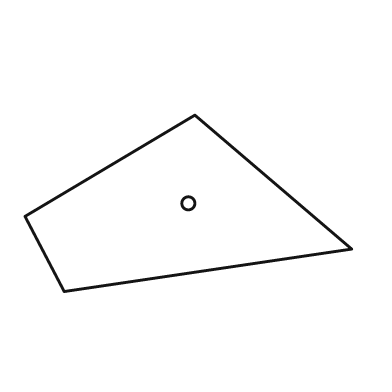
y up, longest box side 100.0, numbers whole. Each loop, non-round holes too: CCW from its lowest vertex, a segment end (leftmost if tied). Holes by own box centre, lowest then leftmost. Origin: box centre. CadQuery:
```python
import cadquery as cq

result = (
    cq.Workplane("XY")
    .moveTo(-38.0, -27.0)
    .lineTo(50.0, -14.0)
    .lineTo(2.0, 27.0)
    .lineTo(-50.0, -4.0)
    .close()
    .moveTo(0.0, 0.0)
    .circle(2.0)
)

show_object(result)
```